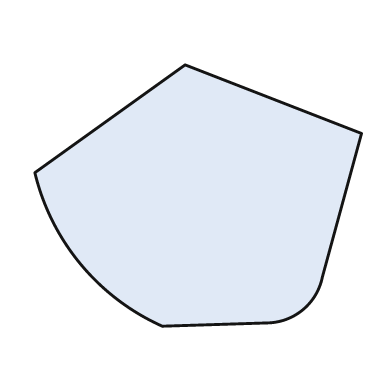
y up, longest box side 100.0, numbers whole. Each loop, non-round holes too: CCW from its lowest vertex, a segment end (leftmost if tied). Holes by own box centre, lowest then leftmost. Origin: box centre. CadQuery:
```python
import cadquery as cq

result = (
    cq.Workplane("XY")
    .moveTo(-11.0, -40.0)
    .lineTo(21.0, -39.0)
    .threePointArc((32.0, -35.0), (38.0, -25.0))
    .lineTo(50.0, 19.0)
    .lineTo(-4.0, 40.0)
    .lineTo(-50.0, 7.0)
    .threePointArc((-36.0, -21.0), (-11.0, -40.0))
    .close()
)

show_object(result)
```